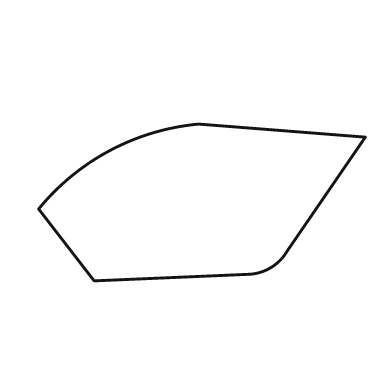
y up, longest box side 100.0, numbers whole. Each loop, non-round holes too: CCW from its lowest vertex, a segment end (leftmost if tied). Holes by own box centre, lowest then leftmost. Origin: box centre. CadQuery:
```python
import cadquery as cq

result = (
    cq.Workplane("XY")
    .moveTo(-33.0, -24.0)
    .lineTo(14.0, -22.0)
    .threePointArc((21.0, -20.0), (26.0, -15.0))
    .lineTo(50.0, 20.0)
    .lineTo(-1.0, 24.0)
    .threePointArc((-28.0, 16.0), (-50.0, -2.0))
    .close()
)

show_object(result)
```